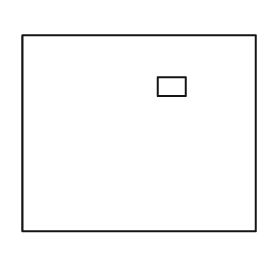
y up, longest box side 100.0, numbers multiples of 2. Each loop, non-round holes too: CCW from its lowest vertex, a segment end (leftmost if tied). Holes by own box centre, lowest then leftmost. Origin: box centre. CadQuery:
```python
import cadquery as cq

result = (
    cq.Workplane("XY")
    .moveTo(-50.0, -42.0)
    .lineTo(50.0, -42.0)
    .lineTo(50.0, 42.0)
    .lineTo(-50.0, 42.0)
    .close()
    .moveTo(8.0, 16.0)
    .lineTo(20.0, 16.0)
    .lineTo(20.0, 24.0)
    .lineTo(8.0, 24.0)
    .close()
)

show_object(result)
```